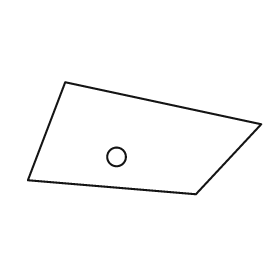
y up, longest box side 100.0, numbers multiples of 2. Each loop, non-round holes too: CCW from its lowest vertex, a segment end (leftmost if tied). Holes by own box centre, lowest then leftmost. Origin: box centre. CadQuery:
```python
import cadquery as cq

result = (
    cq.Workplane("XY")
    .moveTo(22.0, -24.0)
    .lineTo(50.0, 6.0)
    .lineTo(-34.0, 24.0)
    .lineTo(-50.0, -18.0)
    .close()
    .moveTo(-12.0, -8.0)
    .circle(4.0)
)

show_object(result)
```